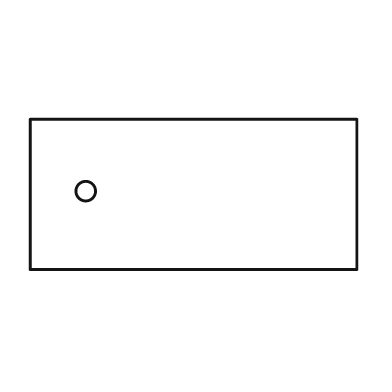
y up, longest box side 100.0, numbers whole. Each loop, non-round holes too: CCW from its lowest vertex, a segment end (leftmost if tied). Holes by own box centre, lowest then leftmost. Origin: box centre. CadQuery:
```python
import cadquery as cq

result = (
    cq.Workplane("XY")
    .moveTo(-50.0, -23.0)
    .lineTo(50.0, -23.0)
    .lineTo(50.0, 23.0)
    .lineTo(-50.0, 23.0)
    .close()
    .moveTo(-33.0, 1.0)
    .circle(3.0)
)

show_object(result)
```